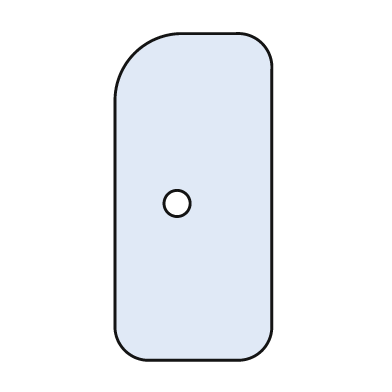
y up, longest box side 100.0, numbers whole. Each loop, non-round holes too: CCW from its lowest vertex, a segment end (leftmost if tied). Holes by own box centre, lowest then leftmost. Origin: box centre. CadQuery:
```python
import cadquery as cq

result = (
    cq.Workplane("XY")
    .moveTo(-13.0, -50.0)
    .lineTo(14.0, -50.0)
    .threePointArc((21.0, -47.0), (24.0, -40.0))
    .lineTo(24.0, 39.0)
    .threePointArc((21.0, 47.0), (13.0, 50.0))
    .lineTo(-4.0, 50.0)
    .threePointArc((-18.0, 44.0), (-24.0, 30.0))
    .lineTo(-24.0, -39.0)
    .threePointArc((-21.0, -47.0), (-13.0, -50.0))
    .close()
    .moveTo(-5.0, -2.0)
    .circle(4.0)
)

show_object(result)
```